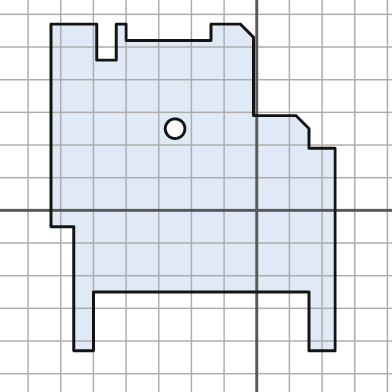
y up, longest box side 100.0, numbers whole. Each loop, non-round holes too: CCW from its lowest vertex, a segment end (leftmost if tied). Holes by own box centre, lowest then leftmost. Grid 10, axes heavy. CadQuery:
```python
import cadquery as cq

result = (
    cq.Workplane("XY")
    .moveTo(-56.0, -43.0)
    .lineTo(-50.0, -43.0)
    .lineTo(-50.0, -25.0)
    .lineTo(16.0, -25.0)
    .lineTo(16.0, -43.0)
    .lineTo(24.0, -43.0)
    .lineTo(24.0, 19.0)
    .lineTo(16.0, 19.0)
    .lineTo(16.0, 25.0)
    .lineTo(12.0, 29.0)
    .lineTo(-1.0, 29.0)
    .lineTo(-1.0, 53.0)
    .lineTo(-5.0, 57.0)
    .lineTo(-14.0, 57.0)
    .lineTo(-14.0, 52.0)
    .lineTo(-40.0, 52.0)
    .lineTo(-40.0, 57.0)
    .lineTo(-43.0, 57.0)
    .lineTo(-43.0, 46.0)
    .lineTo(-49.0, 46.0)
    .lineTo(-49.0, 57.0)
    .lineTo(-63.0, 57.0)
    .lineTo(-63.0, -5.0)
    .lineTo(-56.0, -5.0)
    .close()
    .moveTo(-25.0, 25.0)
    .circle(3.0)
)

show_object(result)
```